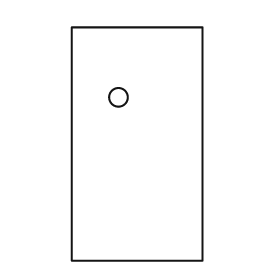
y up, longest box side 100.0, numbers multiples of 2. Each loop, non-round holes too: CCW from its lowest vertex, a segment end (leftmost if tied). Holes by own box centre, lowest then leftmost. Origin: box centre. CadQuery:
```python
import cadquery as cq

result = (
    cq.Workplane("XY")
    .moveTo(-28.0, -50.0)
    .lineTo(28.0, -50.0)
    .lineTo(28.0, 50.0)
    .lineTo(-28.0, 50.0)
    .close()
    .moveTo(-8.0, 20.0)
    .circle(4.0)
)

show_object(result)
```